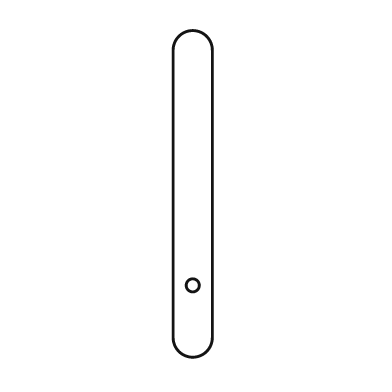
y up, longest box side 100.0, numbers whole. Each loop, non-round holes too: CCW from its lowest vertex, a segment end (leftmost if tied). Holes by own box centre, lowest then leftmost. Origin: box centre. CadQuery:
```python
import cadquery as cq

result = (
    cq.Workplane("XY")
    .moveTo(-6.0, -44.0)
    .threePointArc((0.0, -50.0), (6.0, -44.0))
    .lineTo(6.0, 44.0)
    .threePointArc((0.0, 50.0), (-6.0, 44.0))
    .close()
    .moveTo(0.0, -28.0)
    .circle(2.0)
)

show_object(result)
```